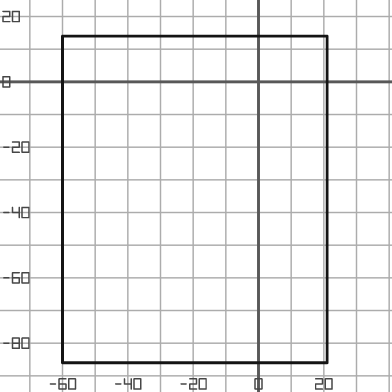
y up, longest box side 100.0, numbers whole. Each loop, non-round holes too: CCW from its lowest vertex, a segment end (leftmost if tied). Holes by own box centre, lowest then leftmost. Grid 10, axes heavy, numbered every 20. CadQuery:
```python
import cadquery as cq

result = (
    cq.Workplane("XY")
    .moveTo(-60.0, -86.0)
    .lineTo(21.0, -86.0)
    .lineTo(21.0, 14.0)
    .lineTo(-60.0, 14.0)
    .close()
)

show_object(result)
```